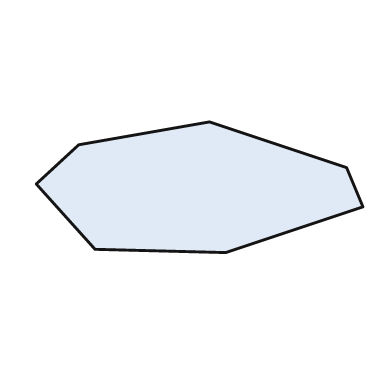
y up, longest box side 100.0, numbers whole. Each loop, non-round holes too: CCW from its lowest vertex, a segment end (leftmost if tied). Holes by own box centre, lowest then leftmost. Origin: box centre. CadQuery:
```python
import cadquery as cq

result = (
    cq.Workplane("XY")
    .moveTo(8.0, -20.0)
    .lineTo(50.0, -6.0)
    .lineTo(45.0, 6.0)
    .lineTo(3.0, 20.0)
    .lineTo(-37.0, 13.0)
    .lineTo(-50.0, 1.0)
    .lineTo(-32.0, -19.0)
    .close()
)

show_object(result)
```